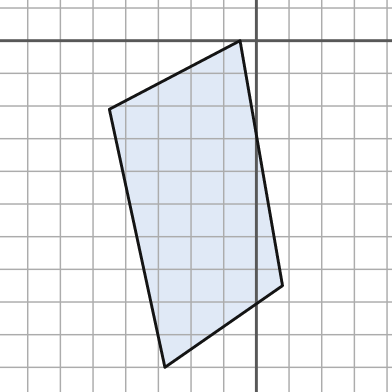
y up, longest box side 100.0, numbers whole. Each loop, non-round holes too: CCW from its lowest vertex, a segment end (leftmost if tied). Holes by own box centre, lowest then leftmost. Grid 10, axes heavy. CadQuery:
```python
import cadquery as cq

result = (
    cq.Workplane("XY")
    .moveTo(-28.0, -100.0)
    .lineTo(8.0, -75.0)
    .lineTo(-5.0, 0.0)
    .lineTo(-45.0, -21.0)
    .close()
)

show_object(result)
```